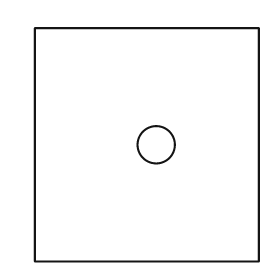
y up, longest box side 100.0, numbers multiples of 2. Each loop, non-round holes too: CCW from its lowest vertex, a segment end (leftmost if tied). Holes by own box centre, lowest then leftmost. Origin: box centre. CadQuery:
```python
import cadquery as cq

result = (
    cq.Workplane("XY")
    .moveTo(-48.0, -50.0)
    .lineTo(48.0, -50.0)
    .lineTo(48.0, 50.0)
    .lineTo(-48.0, 50.0)
    .close()
    .moveTo(4.0, 0.0)
    .circle(8.0)
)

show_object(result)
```